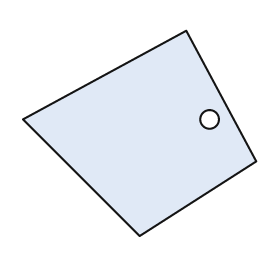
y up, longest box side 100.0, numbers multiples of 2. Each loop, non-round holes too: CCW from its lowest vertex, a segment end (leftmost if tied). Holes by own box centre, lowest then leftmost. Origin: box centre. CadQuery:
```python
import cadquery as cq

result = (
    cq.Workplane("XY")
    .moveTo(0.0, -44.0)
    .lineTo(50.0, -12.0)
    .lineTo(20.0, 44.0)
    .lineTo(-50.0, 6.0)
    .close()
    .moveTo(30.0, 6.0)
    .circle(4.0)
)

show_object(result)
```